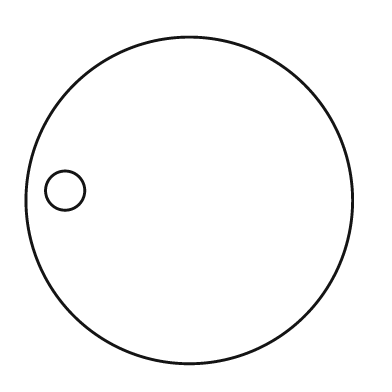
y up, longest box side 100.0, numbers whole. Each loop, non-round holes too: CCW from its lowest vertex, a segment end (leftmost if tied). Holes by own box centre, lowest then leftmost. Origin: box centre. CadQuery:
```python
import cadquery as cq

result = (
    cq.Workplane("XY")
    .moveTo(0.0, 0.0)
    .circle(50.0)
    .moveTo(-38.0, 3.0)
    .circle(6.0)
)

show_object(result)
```